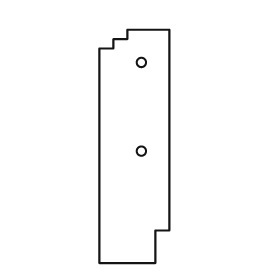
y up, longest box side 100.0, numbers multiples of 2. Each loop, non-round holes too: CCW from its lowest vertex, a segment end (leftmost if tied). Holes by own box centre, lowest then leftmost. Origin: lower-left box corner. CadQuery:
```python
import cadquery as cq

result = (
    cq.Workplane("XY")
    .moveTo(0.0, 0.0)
    .lineTo(24.0, 0.0)
    .lineTo(24.0, 14.0)
    .lineTo(30.0, 14.0)
    .lineTo(30.0, 100.0)
    .lineTo(12.0, 100.0)
    .lineTo(12.0, 96.0)
    .lineTo(6.0, 96.0)
    .lineTo(6.0, 92.0)
    .lineTo(0.0, 92.0)
    .close()
    .moveTo(18.0, 48.0)
    .circle(2.0)
    .moveTo(18.0, 86.0)
    .circle(2.0)
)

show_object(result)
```